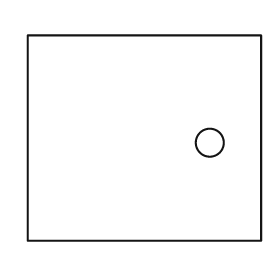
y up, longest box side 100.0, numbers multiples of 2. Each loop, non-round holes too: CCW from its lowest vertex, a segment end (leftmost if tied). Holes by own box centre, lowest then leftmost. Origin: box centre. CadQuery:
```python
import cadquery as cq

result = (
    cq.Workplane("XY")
    .moveTo(-50.0, -44.0)
    .lineTo(50.0, -44.0)
    .lineTo(50.0, 44.0)
    .lineTo(-50.0, 44.0)
    .close()
    .moveTo(28.0, -2.0)
    .circle(6.0)
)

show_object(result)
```